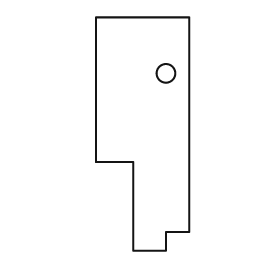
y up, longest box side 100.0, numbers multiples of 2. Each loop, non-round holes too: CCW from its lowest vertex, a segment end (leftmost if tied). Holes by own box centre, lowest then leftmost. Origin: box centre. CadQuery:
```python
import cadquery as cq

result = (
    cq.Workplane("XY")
    .moveTo(-4.0, -50.0)
    .lineTo(10.0, -50.0)
    .lineTo(10.0, -42.0)
    .lineTo(20.0, -42.0)
    .lineTo(20.0, 50.0)
    .lineTo(-20.0, 50.0)
    .lineTo(-20.0, -12.0)
    .lineTo(-4.0, -12.0)
    .close()
    .moveTo(10.0, 26.0)
    .circle(4.0)
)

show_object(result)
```